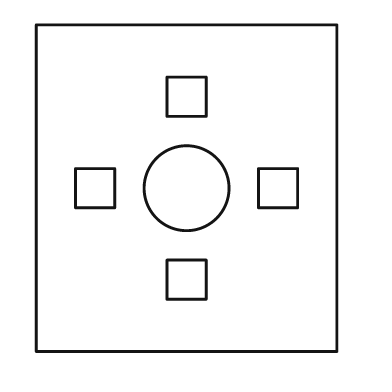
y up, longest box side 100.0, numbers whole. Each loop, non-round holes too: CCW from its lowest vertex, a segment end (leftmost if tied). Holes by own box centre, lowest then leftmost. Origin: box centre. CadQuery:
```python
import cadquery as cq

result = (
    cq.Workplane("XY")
    .moveTo(-46.0, -50.0)
    .lineTo(46.0, -50.0)
    .lineTo(46.0, 50.0)
    .lineTo(-46.0, 50.0)
    .close()
    .moveTo(-6.0, -34.0)
    .lineTo(6.0, -34.0)
    .lineTo(6.0, -22.0)
    .lineTo(-6.0, -22.0)
    .close()
    .moveTo(-34.0, -6.0)
    .lineTo(-22.0, -6.0)
    .lineTo(-22.0, 6.0)
    .lineTo(-34.0, 6.0)
    .close()
    .moveTo(0.0, 0.0)
    .circle(13.0)
    .moveTo(22.0, -6.0)
    .lineTo(34.0, -6.0)
    .lineTo(34.0, 6.0)
    .lineTo(22.0, 6.0)
    .close()
    .moveTo(-6.0, 22.0)
    .lineTo(6.0, 22.0)
    .lineTo(6.0, 34.0)
    .lineTo(-6.0, 34.0)
    .close()
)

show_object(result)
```